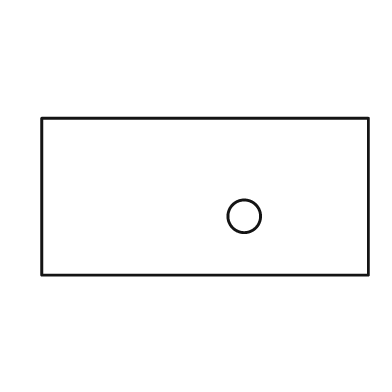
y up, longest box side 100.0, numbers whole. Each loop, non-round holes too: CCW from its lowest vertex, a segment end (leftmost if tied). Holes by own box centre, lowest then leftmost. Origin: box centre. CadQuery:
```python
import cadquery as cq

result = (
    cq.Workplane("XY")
    .moveTo(-50.0, -24.0)
    .lineTo(50.0, -24.0)
    .lineTo(50.0, 24.0)
    .lineTo(-50.0, 24.0)
    .close()
    .moveTo(12.0, -6.0)
    .circle(5.0)
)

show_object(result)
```